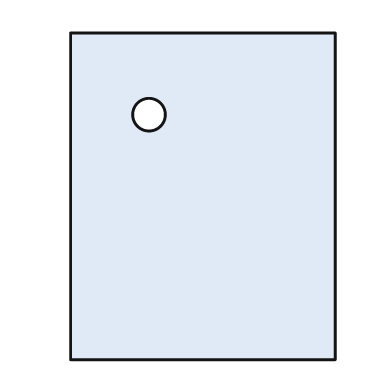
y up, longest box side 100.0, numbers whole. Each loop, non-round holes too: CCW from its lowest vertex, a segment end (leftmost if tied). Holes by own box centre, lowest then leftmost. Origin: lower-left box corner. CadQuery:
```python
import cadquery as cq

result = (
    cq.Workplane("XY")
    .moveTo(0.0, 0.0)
    .lineTo(81.0, 0.0)
    .lineTo(81.0, 100.0)
    .lineTo(0.0, 100.0)
    .close()
    .moveTo(24.0, 75.0)
    .circle(5.0)
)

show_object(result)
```